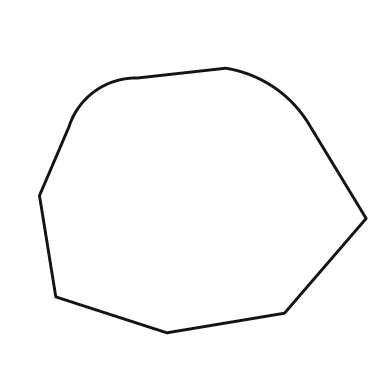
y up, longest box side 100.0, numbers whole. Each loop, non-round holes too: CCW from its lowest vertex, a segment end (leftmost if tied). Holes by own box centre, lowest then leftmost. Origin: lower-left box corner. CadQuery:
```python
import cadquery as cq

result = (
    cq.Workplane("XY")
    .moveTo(39.0, 0.0)
    .lineTo(75.0, 6.0)
    .lineTo(100.0, 35.0)
    .lineTo(83.0, 63.0)
    .threePointArc((72.0, 75.0), (57.0, 81.0))
    .lineTo(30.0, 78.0)
    .threePointArc((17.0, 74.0), (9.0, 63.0))
    .lineTo(0.0, 42.0)
    .lineTo(5.0, 11.0)
    .close()
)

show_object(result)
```